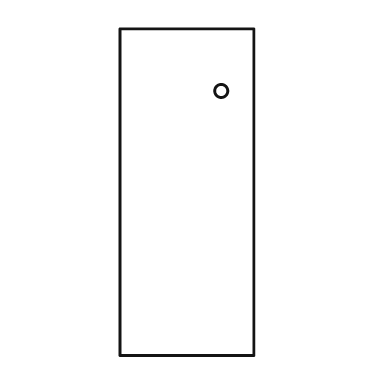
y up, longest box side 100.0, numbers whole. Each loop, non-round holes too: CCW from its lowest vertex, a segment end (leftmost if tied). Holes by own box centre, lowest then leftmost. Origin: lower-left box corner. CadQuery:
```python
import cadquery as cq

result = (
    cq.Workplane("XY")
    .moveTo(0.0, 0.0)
    .lineTo(41.0, 0.0)
    .lineTo(41.0, 100.0)
    .lineTo(0.0, 100.0)
    .close()
    .moveTo(31.0, 81.0)
    .circle(2.0)
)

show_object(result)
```